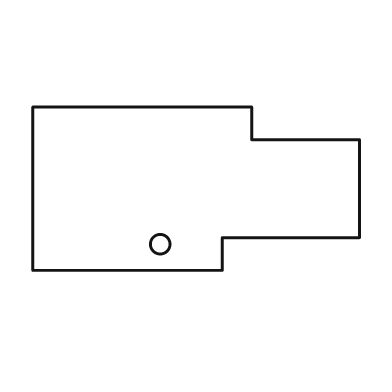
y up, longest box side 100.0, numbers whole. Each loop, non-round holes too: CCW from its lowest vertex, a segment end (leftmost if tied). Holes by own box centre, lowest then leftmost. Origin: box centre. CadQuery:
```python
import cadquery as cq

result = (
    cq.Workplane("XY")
    .moveTo(-50.0, -25.0)
    .lineTo(8.0, -25.0)
    .lineTo(8.0, -15.0)
    .lineTo(50.0, -15.0)
    .lineTo(50.0, 15.0)
    .lineTo(17.0, 15.0)
    .lineTo(17.0, 25.0)
    .lineTo(-50.0, 25.0)
    .close()
    .moveTo(-11.0, -17.0)
    .circle(3.0)
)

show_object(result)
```